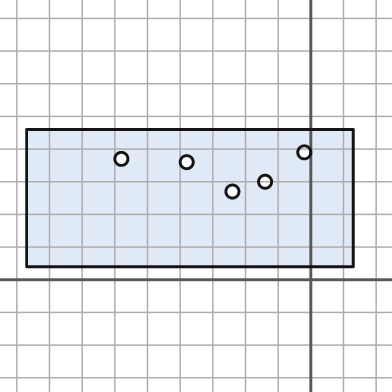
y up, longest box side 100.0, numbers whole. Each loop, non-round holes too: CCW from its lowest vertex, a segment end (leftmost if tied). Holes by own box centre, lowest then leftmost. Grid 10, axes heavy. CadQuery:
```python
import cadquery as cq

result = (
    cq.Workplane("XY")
    .moveTo(-87.0, 4.0)
    .lineTo(13.0, 4.0)
    .lineTo(13.0, 46.0)
    .lineTo(-87.0, 46.0)
    .close()
    .moveTo(-24.0, 27.0)
    .circle(2.0)
    .moveTo(-14.0, 30.0)
    .circle(2.0)
    .moveTo(-38.0, 36.0)
    .circle(2.0)
    .moveTo(-58.0, 37.0)
    .circle(2.0)
    .moveTo(-2.0, 39.0)
    .circle(2.0)
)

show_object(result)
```